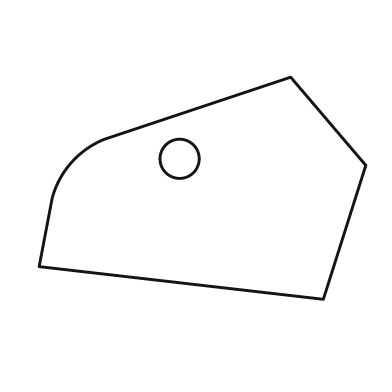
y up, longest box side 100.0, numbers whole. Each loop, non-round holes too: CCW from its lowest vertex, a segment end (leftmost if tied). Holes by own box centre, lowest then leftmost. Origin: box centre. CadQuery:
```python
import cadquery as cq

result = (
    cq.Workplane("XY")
    .moveTo(37.0, -34.0)
    .lineTo(50.0, 7.0)
    .lineTo(27.0, 34.0)
    .lineTo(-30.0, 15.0)
    .threePointArc((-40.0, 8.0), (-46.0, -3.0))
    .lineTo(-50.0, -24.0)
    .close()
    .moveTo(-7.0, 9.0)
    .circle(6.0)
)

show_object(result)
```